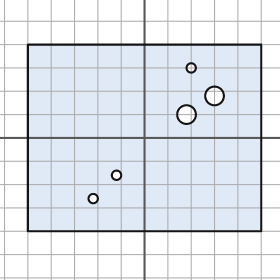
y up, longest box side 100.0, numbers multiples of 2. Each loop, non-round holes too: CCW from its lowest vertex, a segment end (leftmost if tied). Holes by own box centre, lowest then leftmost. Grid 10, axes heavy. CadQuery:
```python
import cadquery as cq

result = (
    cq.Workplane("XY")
    .moveTo(-50.0, -40.0)
    .lineTo(50.0, -40.0)
    .lineTo(50.0, 40.0)
    .lineTo(-50.0, 40.0)
    .close()
    .moveTo(-22.0, -26.0)
    .circle(2.0)
    .moveTo(-12.0, -16.0)
    .circle(2.0)
    .moveTo(18.0, 10.0)
    .circle(4.0)
    .moveTo(30.0, 18.0)
    .circle(4.0)
    .moveTo(20.0, 30.0)
    .circle(2.0)
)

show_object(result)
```